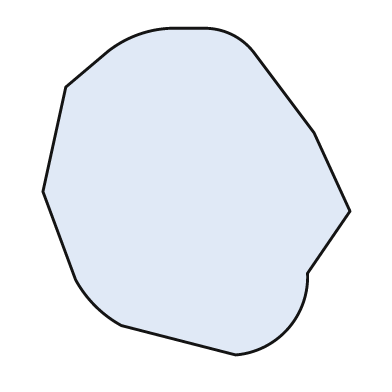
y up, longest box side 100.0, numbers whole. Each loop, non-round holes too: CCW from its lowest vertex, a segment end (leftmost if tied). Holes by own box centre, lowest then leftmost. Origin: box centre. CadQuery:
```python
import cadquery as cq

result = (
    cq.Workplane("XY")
    .moveTo(12.0, -50.0)
    .threePointArc((28.0, -42.0), (34.0, -25.0))
    .lineTo(47.0, -6.0)
    .lineTo(36.0, 18.0)
    .lineTo(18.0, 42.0)
    .threePointArc((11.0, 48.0), (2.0, 50.0))
    .lineTo(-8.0, 50.0)
    .threePointArc((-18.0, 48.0), (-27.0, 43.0))
    .lineTo(-40.0, 32.0)
    .lineTo(-47.0, 0.0)
    .lineTo(-37.0, -27.0)
    .threePointArc((-31.0, -35.0), (-23.0, -41.0))
    .close()
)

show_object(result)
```